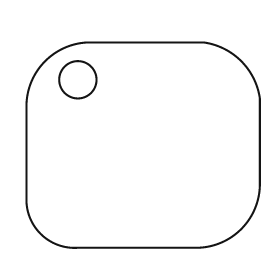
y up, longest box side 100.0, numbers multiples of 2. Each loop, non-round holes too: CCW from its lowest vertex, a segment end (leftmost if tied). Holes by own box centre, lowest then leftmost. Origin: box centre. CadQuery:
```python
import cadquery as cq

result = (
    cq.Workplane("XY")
    .moveTo(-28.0, -44.0)
    .lineTo(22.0, -44.0)
    .threePointArc((42.0, -36.0), (50.0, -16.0))
    .lineTo(50.0, 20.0)
    .threePointArc((42.0, 36.0), (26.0, 44.0))
    .lineTo(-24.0, 44.0)
    .threePointArc((-42.0, 36.0), (-50.0, 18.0))
    .lineTo(-50.0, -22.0)
    .threePointArc((-44.0, -38.0), (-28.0, -44.0))
    .close()
    .moveTo(-28.0, 28.0)
    .circle(8.0)
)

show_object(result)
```